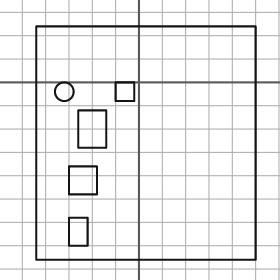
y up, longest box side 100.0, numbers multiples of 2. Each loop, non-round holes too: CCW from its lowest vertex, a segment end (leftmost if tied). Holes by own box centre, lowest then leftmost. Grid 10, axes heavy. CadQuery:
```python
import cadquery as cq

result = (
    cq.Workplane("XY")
    .moveTo(-44.0, -76.0)
    .lineTo(50.0, -76.0)
    .lineTo(50.0, 24.0)
    .lineTo(-44.0, 24.0)
    .close()
    .moveTo(-30.0, -70.0)
    .lineTo(-22.0, -70.0)
    .lineTo(-22.0, -58.0)
    .lineTo(-30.0, -58.0)
    .close()
    .moveTo(-30.0, -48.0)
    .lineTo(-18.0, -48.0)
    .lineTo(-18.0, -36.0)
    .lineTo(-30.0, -36.0)
    .close()
    .moveTo(-26.0, -28.0)
    .lineTo(-14.0, -28.0)
    .lineTo(-14.0, -12.0)
    .lineTo(-26.0, -12.0)
    .close()
    .moveTo(-32.0, -4.0)
    .circle(4.0)
    .moveTo(-10.0, -8.0)
    .lineTo(-2.0, -8.0)
    .lineTo(-2.0, 0.0)
    .lineTo(-10.0, 0.0)
    .close()
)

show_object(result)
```